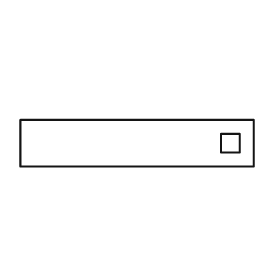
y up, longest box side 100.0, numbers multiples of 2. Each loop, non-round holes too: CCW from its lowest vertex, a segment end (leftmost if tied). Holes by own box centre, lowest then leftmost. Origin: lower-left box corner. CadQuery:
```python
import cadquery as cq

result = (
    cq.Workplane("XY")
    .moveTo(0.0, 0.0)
    .lineTo(100.0, 0.0)
    .lineTo(100.0, 20.0)
    .lineTo(0.0, 20.0)
    .close()
    .moveTo(86.0, 6.0)
    .lineTo(94.0, 6.0)
    .lineTo(94.0, 14.0)
    .lineTo(86.0, 14.0)
    .close()
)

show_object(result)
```